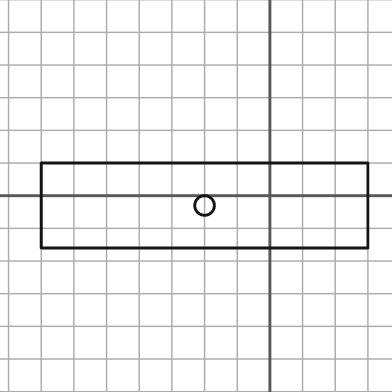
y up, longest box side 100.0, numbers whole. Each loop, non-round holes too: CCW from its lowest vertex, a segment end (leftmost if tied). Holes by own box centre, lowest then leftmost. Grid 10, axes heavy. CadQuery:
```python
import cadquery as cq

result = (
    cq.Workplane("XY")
    .moveTo(-70.0, -16.0)
    .lineTo(30.0, -16.0)
    .lineTo(30.0, 10.0)
    .lineTo(-70.0, 10.0)
    .close()
    .moveTo(-20.0, -3.0)
    .circle(3.0)
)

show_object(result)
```